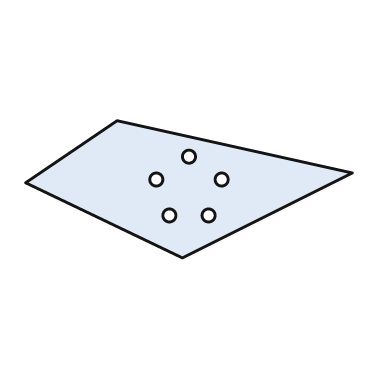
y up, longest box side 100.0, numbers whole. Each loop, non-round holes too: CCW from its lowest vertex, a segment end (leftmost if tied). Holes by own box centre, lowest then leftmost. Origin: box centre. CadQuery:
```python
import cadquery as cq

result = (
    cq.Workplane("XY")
    .moveTo(-2.0, -21.0)
    .lineTo(50.0, 5.0)
    .lineTo(-22.0, 21.0)
    .lineTo(-50.0, 2.0)
    .close()
    .moveTo(-6.0, -8.0)
    .circle(2.0)
    .moveTo(6.0, -8.0)
    .circle(2.0)
    .moveTo(-10.0, 3.0)
    .circle(2.0)
    .moveTo(10.0, 3.0)
    .circle(2.0)
    .moveTo(0.0, 10.0)
    .circle(2.0)
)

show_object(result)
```